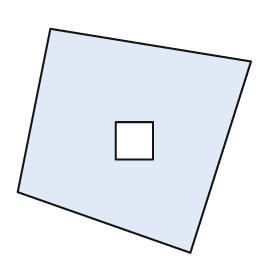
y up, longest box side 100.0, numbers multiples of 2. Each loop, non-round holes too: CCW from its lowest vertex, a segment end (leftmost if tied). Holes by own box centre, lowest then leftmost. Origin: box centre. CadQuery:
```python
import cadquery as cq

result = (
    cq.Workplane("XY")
    .moveTo(24.0, -48.0)
    .lineTo(50.0, 34.0)
    .lineTo(-36.0, 48.0)
    .lineTo(-50.0, -22.0)
    .close()
    .moveTo(-8.0, -8.0)
    .lineTo(8.0, -8.0)
    .lineTo(8.0, 8.0)
    .lineTo(-8.0, 8.0)
    .close()
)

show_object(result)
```